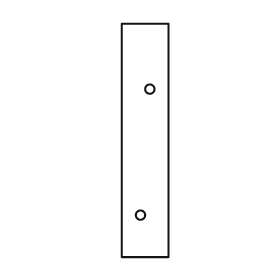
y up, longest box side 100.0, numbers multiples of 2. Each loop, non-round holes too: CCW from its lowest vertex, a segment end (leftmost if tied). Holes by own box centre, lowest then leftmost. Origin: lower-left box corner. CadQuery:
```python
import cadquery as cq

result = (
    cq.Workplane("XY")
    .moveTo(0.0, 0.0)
    .lineTo(20.0, 0.0)
    .lineTo(20.0, 100.0)
    .lineTo(0.0, 100.0)
    .close()
    .moveTo(8.0, 18.0)
    .circle(2.0)
    .moveTo(12.0, 72.0)
    .circle(2.0)
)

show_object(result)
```